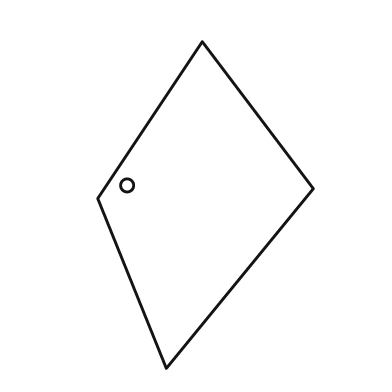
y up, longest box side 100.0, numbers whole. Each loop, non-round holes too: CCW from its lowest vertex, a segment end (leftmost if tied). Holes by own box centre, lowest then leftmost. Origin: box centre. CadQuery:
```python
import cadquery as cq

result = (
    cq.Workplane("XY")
    .moveTo(-12.0, -50.0)
    .lineTo(33.0, 5.0)
    .lineTo(-1.0, 50.0)
    .lineTo(-33.0, 2.0)
    .close()
    .moveTo(-24.0, 6.0)
    .circle(2.0)
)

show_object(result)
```